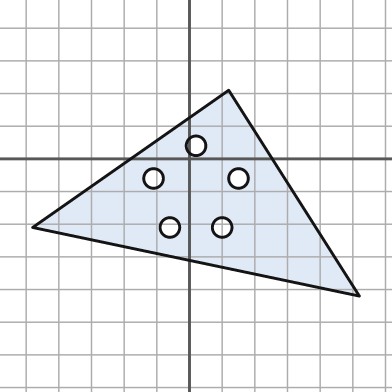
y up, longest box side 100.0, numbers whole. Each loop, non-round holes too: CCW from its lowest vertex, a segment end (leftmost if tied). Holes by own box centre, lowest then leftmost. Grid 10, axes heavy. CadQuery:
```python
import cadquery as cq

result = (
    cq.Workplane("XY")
    .moveTo(52.0, -42.0)
    .lineTo(12.0, 21.0)
    .lineTo(-48.0, -21.0)
    .close()
    .moveTo(-6.0, -21.0)
    .circle(3.0)
    .moveTo(10.0, -21.0)
    .circle(3.0)
    .moveTo(-11.0, -6.0)
    .circle(3.0)
    .moveTo(15.0, -6.0)
    .circle(3.0)
    .moveTo(2.0, 4.0)
    .circle(3.0)
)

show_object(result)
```